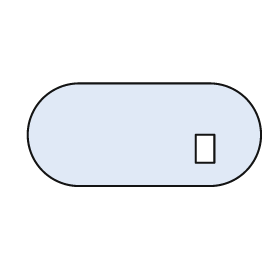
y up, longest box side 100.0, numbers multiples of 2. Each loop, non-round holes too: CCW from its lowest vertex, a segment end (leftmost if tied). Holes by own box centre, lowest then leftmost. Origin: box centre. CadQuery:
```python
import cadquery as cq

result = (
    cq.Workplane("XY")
    .moveTo(-28.0, -22.0)
    .lineTo(28.0, -22.0)
    .threePointArc((50.0, 0.0), (28.0, 22.0))
    .lineTo(-28.0, 22.0)
    .threePointArc((-50.0, 0.0), (-28.0, -22.0))
    .close()
    .moveTo(22.0, -12.0)
    .lineTo(30.0, -12.0)
    .lineTo(30.0, 0.0)
    .lineTo(22.0, 0.0)
    .close()
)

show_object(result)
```